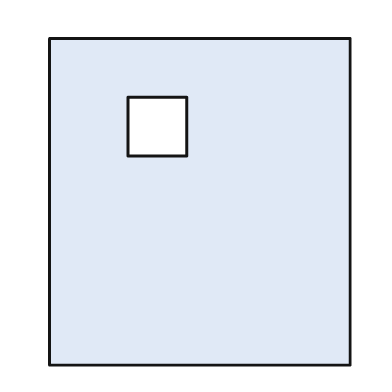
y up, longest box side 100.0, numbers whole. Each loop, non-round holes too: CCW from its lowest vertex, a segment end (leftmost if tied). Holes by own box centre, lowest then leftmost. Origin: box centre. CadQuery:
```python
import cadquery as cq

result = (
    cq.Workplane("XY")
    .moveTo(-46.0, -50.0)
    .lineTo(46.0, -50.0)
    .lineTo(46.0, 50.0)
    .lineTo(-46.0, 50.0)
    .close()
    .moveTo(-22.0, 14.0)
    .lineTo(-4.0, 14.0)
    .lineTo(-4.0, 32.0)
    .lineTo(-22.0, 32.0)
    .close()
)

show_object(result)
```